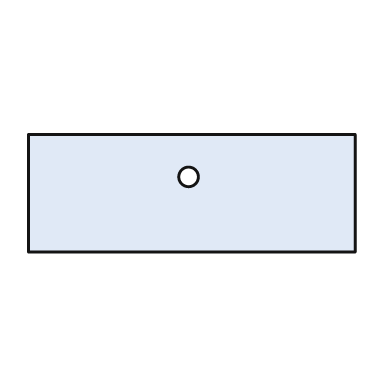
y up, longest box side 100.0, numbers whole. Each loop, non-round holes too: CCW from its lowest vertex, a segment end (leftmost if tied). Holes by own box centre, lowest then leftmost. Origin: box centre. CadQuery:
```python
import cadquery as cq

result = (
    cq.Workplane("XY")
    .moveTo(-50.0, -18.0)
    .lineTo(50.0, -18.0)
    .lineTo(50.0, 18.0)
    .lineTo(-50.0, 18.0)
    .close()
    .moveTo(-1.0, 5.0)
    .circle(3.0)
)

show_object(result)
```